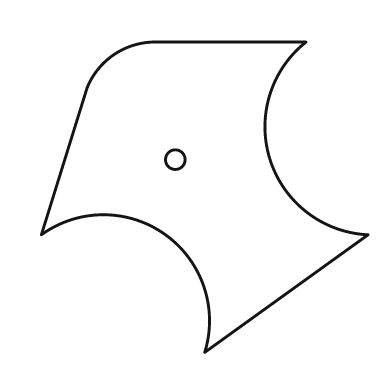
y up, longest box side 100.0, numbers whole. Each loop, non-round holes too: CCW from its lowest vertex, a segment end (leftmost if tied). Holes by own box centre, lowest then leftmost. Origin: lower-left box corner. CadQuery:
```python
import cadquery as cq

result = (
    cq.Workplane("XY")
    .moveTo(50.0, 0.0)
    .lineTo(100.0, 36.0)
    .threePointArc((70.0, 59.0), (81.0, 95.0))
    .lineTo(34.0, 95.0)
    .threePointArc((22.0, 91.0), (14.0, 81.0))
    .lineTo(0.0, 36.0)
    .threePointArc((38.0, 36.0), (50.0, 0.0))
    .close()
    .moveTo(41.0, 59.0)
    .circle(3.0)
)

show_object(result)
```